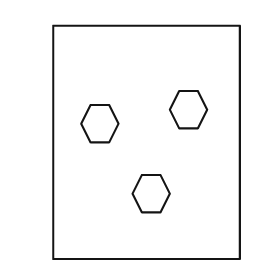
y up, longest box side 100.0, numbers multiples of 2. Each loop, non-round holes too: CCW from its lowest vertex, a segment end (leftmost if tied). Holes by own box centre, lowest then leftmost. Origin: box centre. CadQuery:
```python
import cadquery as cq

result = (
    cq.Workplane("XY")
    .moveTo(-40.0, -50.0)
    .lineTo(40.0, -50.0)
    .lineTo(40.0, 50.0)
    .lineTo(-40.0, 50.0)
    .close()
    .moveTo(-2.0, -30.0)
    .lineTo(6.0, -30.0)
    .lineTo(10.0, -22.0)
    .lineTo(6.0, -14.0)
    .lineTo(-2.0, -14.0)
    .lineTo(-6.0, -22.0)
    .close()
    .moveTo(-24.0, 0.0)
    .lineTo(-16.0, 0.0)
    .lineTo(-12.0, 8.0)
    .lineTo(-16.0, 16.0)
    .lineTo(-24.0, 16.0)
    .lineTo(-28.0, 8.0)
    .close()
    .moveTo(14.0, 6.0)
    .lineTo(22.0, 6.0)
    .lineTo(26.0, 14.0)
    .lineTo(22.0, 22.0)
    .lineTo(14.0, 22.0)
    .lineTo(10.0, 14.0)
    .close()
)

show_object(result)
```